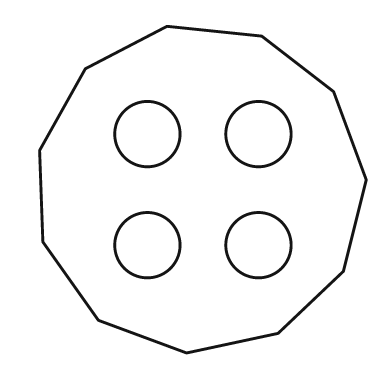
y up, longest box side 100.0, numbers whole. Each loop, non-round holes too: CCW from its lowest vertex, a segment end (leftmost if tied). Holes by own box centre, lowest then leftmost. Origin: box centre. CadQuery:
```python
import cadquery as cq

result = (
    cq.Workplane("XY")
    .moveTo(-5.0, -50.0)
    .lineTo(23.0, -44.0)
    .lineTo(43.0, -25.0)
    .lineTo(50.0, 3.0)
    .lineTo(40.0, 30.0)
    .lineTo(18.0, 47.0)
    .lineTo(-11.0, 50.0)
    .lineTo(-36.0, 37.0)
    .lineTo(-50.0, 12.0)
    .lineTo(-49.0, -16.0)
    .lineTo(-32.0, -40.0)
    .close()
    .moveTo(-17.0, -17.0)
    .circle(10.0)
    .moveTo(17.0, -17.0)
    .circle(10.0)
    .moveTo(-17.0, 17.0)
    .circle(10.0)
    .moveTo(17.0, 17.0)
    .circle(10.0)
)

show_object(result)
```